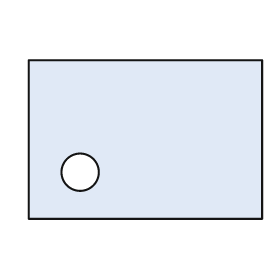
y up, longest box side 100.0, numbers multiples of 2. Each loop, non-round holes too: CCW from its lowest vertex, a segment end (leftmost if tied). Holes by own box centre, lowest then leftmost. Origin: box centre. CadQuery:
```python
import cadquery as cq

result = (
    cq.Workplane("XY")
    .moveTo(-50.0, -34.0)
    .lineTo(50.0, -34.0)
    .lineTo(50.0, 34.0)
    .lineTo(-50.0, 34.0)
    .close()
    .moveTo(-28.0, -14.0)
    .circle(8.0)
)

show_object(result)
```